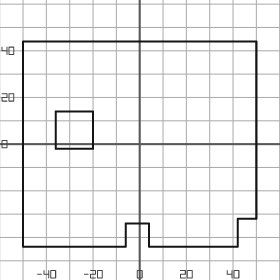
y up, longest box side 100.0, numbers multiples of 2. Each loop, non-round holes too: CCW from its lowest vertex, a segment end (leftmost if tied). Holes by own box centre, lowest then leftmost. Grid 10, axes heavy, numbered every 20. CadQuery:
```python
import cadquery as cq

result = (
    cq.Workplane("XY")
    .moveTo(-50.0, -44.0)
    .lineTo(-6.0, -44.0)
    .lineTo(-6.0, -34.0)
    .lineTo(4.0, -34.0)
    .lineTo(4.0, -44.0)
    .lineTo(42.0, -44.0)
    .lineTo(42.0, -32.0)
    .lineTo(50.0, -32.0)
    .lineTo(50.0, 44.0)
    .lineTo(-50.0, 44.0)
    .close()
    .moveTo(-36.0, -2.0)
    .lineTo(-20.0, -2.0)
    .lineTo(-20.0, 14.0)
    .lineTo(-36.0, 14.0)
    .close()
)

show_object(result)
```